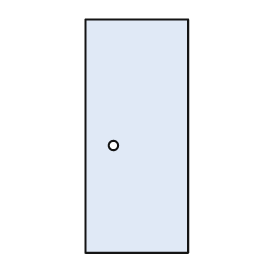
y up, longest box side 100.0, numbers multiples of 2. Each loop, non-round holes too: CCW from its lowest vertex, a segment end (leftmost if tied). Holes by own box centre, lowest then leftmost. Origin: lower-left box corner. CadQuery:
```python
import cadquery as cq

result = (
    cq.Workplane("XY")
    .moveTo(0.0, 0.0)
    .lineTo(44.0, 0.0)
    .lineTo(44.0, 100.0)
    .lineTo(0.0, 100.0)
    .close()
    .moveTo(12.0, 46.0)
    .circle(2.0)
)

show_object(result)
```